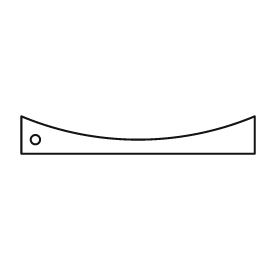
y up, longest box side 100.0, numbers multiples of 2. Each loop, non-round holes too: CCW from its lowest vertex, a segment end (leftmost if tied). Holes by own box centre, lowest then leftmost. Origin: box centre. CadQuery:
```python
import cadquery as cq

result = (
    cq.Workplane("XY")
    .moveTo(-50.0, -8.0)
    .lineTo(50.0, -8.0)
    .lineTo(50.0, 8.0)
    .threePointArc((0.0, -2.0), (-50.0, 8.0))
    .close()
    .moveTo(-44.0, -2.0)
    .circle(2.0)
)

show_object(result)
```